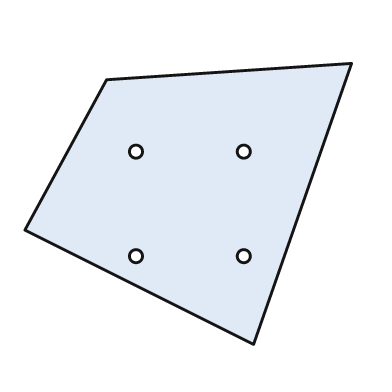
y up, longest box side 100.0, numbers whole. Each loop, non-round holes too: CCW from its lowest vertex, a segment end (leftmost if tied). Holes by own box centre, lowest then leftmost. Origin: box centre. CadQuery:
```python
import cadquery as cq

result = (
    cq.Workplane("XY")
    .moveTo(20.0, -43.0)
    .lineTo(50.0, 43.0)
    .lineTo(-25.0, 38.0)
    .lineTo(-50.0, -8.0)
    .close()
    .moveTo(-16.0, -16.0)
    .circle(2.0)
    .moveTo(17.0, -16.0)
    .circle(2.0)
    .moveTo(-16.0, 16.0)
    .circle(2.0)
    .moveTo(17.0, 16.0)
    .circle(2.0)
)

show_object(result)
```